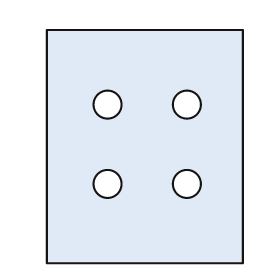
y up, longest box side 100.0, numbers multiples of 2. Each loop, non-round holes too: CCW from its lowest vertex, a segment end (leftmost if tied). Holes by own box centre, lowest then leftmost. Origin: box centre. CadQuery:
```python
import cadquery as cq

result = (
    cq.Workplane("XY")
    .moveTo(-42.0, -50.0)
    .lineTo(42.0, -50.0)
    .lineTo(42.0, 50.0)
    .lineTo(-42.0, 50.0)
    .close()
    .moveTo(-16.0, -16.0)
    .circle(6.0)
    .moveTo(18.0, -16.0)
    .circle(6.0)
    .moveTo(-16.0, 18.0)
    .circle(6.0)
    .moveTo(18.0, 18.0)
    .circle(6.0)
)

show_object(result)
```